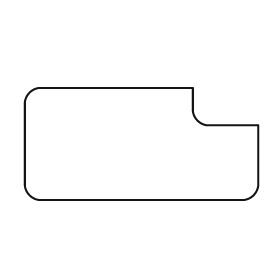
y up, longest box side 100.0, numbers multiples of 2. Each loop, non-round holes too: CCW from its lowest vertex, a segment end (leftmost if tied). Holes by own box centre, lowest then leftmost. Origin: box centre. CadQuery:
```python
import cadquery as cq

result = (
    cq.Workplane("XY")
    .moveTo(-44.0, -24.0)
    .lineTo(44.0, -24.0)
    .threePointArc((48.0, -22.0), (50.0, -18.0))
    .lineTo(50.0, 8.0)
    .lineTo(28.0, 8.0)
    .threePointArc((24.0, 10.0), (22.0, 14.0))
    .lineTo(22.0, 24.0)
    .lineTo(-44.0, 24.0)
    .threePointArc((-48.0, 22.0), (-50.0, 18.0))
    .lineTo(-50.0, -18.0)
    .threePointArc((-48.0, -22.0), (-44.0, -24.0))
    .close()
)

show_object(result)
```